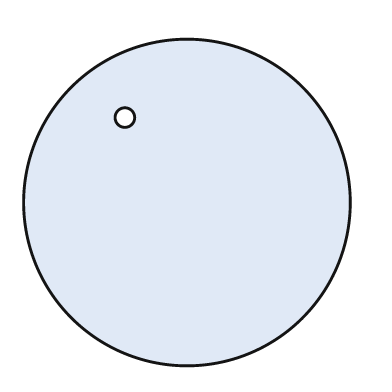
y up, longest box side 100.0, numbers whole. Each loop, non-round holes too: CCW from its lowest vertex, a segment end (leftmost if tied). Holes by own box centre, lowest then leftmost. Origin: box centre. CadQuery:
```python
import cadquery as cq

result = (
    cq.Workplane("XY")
    .moveTo(0.0, 0.0)
    .circle(50.0)
    .moveTo(-19.0, 26.0)
    .circle(3.0)
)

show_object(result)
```